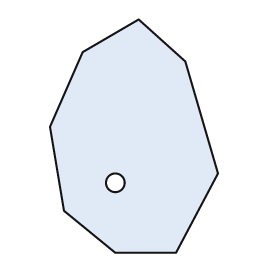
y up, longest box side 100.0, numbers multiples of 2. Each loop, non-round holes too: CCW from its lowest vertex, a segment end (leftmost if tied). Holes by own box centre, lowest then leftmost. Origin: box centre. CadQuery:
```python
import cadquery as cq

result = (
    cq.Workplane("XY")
    .moveTo(-8.0, -50.0)
    .lineTo(18.0, -50.0)
    .lineTo(36.0, -16.0)
    .lineTo(22.0, 32.0)
    .lineTo(2.0, 50.0)
    .lineTo(-22.0, 36.0)
    .lineTo(-36.0, 4.0)
    .lineTo(-30.0, -32.0)
    .close()
    .moveTo(-8.0, -20.0)
    .circle(4.0)
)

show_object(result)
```